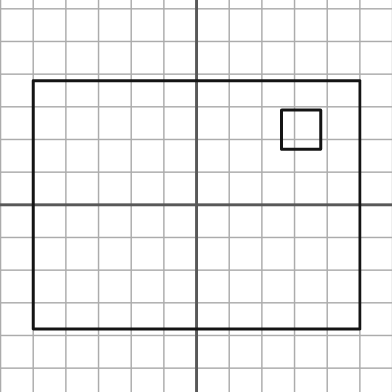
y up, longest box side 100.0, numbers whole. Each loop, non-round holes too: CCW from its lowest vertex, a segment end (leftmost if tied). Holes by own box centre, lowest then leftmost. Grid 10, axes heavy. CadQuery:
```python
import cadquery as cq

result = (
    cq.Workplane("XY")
    .moveTo(-50.0, -38.0)
    .lineTo(50.0, -38.0)
    .lineTo(50.0, 38.0)
    .lineTo(-50.0, 38.0)
    .close()
    .moveTo(26.0, 17.0)
    .lineTo(38.0, 17.0)
    .lineTo(38.0, 29.0)
    .lineTo(26.0, 29.0)
    .close()
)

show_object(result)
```